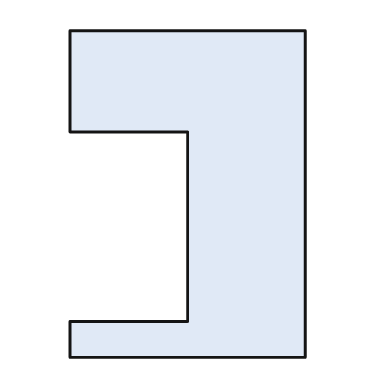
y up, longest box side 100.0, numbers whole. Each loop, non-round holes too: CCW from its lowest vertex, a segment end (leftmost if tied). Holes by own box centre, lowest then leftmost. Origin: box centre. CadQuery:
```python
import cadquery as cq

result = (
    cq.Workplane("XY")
    .moveTo(-36.0, -50.0)
    .lineTo(36.0, -50.0)
    .lineTo(36.0, 50.0)
    .lineTo(-36.0, 50.0)
    .lineTo(-36.0, 19.0)
    .lineTo(0.0, 19.0)
    .lineTo(0.0, -39.0)
    .lineTo(-36.0, -39.0)
    .close()
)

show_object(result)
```